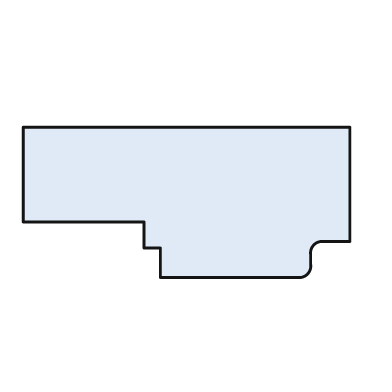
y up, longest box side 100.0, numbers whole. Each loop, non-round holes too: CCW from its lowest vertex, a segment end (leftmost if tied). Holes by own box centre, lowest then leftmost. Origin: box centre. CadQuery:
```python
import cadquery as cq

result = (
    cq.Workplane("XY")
    .moveTo(-8.0, -23.0)
    .lineTo(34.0, -23.0)
    .threePointArc((37.0, -22.0), (38.0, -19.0))
    .lineTo(38.0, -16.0)
    .threePointArc((39.0, -13.0), (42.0, -12.0))
    .lineTo(50.0, -12.0)
    .lineTo(50.0, 23.0)
    .lineTo(-50.0, 23.0)
    .lineTo(-50.0, -6.0)
    .lineTo(-13.0, -6.0)
    .lineTo(-13.0, -14.0)
    .lineTo(-8.0, -14.0)
    .close()
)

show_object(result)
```